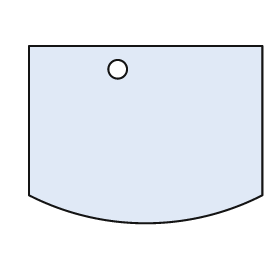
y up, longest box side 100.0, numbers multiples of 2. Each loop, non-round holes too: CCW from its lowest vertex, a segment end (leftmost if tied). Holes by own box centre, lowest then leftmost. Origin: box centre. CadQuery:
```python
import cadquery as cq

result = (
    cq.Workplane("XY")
    .moveTo(-50.0, -26.0)
    .threePointArc((0.0, -38.0), (50.0, -26.0))
    .lineTo(50.0, 38.0)
    .lineTo(-50.0, 38.0)
    .close()
    .moveTo(-12.0, 28.0)
    .circle(4.0)
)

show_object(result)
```